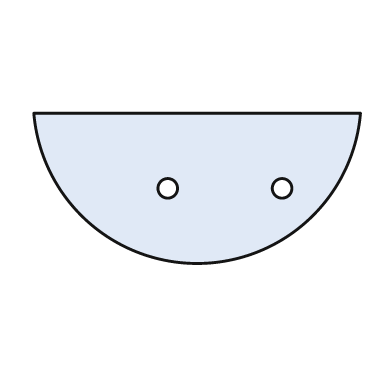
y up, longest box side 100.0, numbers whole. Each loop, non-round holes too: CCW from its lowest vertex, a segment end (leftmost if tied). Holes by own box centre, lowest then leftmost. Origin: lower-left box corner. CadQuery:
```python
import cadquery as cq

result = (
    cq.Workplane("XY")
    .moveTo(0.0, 46.0)
    .threePointArc((50.0, 0.0), (100.0, 46.0))
    .close()
    .moveTo(41.0, 23.0)
    .circle(3.0)
    .moveTo(76.0, 23.0)
    .circle(3.0)
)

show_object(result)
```